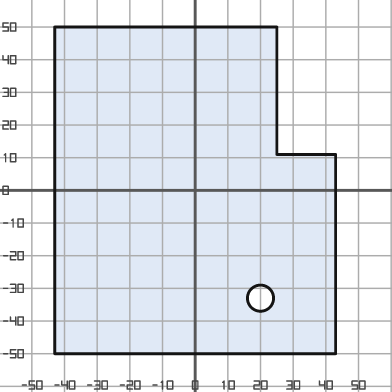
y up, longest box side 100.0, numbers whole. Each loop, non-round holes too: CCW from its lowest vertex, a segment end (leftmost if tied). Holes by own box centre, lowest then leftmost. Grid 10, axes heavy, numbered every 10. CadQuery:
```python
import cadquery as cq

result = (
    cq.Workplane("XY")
    .moveTo(-43.0, -50.0)
    .lineTo(43.0, -50.0)
    .lineTo(43.0, 11.0)
    .lineTo(25.0, 11.0)
    .lineTo(25.0, 50.0)
    .lineTo(-43.0, 50.0)
    .close()
    .moveTo(20.0, -33.0)
    .circle(4.0)
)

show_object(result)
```